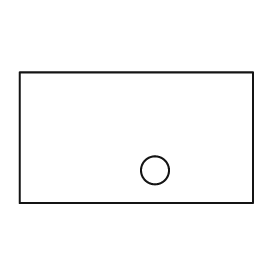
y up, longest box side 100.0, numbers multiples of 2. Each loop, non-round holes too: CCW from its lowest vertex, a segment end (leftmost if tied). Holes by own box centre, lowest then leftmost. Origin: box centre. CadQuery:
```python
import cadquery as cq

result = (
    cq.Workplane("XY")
    .moveTo(-50.0, -28.0)
    .lineTo(50.0, -28.0)
    .lineTo(50.0, 28.0)
    .lineTo(-50.0, 28.0)
    .close()
    .moveTo(8.0, -14.0)
    .circle(6.0)
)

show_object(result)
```